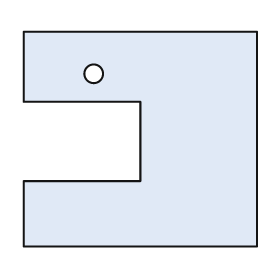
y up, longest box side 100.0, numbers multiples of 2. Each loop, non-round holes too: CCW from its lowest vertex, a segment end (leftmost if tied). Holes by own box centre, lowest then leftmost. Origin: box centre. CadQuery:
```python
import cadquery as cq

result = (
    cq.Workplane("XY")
    .moveTo(-50.0, -46.0)
    .lineTo(50.0, -46.0)
    .lineTo(50.0, 46.0)
    .lineTo(-50.0, 46.0)
    .lineTo(-50.0, 16.0)
    .lineTo(0.0, 16.0)
    .lineTo(0.0, -18.0)
    .lineTo(-50.0, -18.0)
    .close()
    .moveTo(-20.0, 28.0)
    .circle(4.0)
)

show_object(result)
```